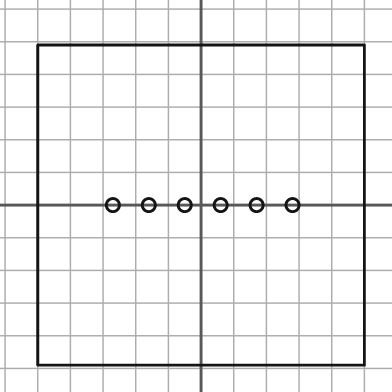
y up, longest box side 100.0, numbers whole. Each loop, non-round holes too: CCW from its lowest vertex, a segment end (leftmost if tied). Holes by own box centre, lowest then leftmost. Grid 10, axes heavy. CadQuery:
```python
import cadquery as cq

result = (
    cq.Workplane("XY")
    .moveTo(-50.0, -49.0)
    .lineTo(50.0, -49.0)
    .lineTo(50.0, 49.0)
    .lineTo(-50.0, 49.0)
    .close()
    .moveTo(-27.0, 0.0)
    .circle(2.0)
    .moveTo(-16.0, 0.0)
    .circle(2.0)
    .moveTo(-5.0, 0.0)
    .circle(2.0)
    .moveTo(6.0, 0.0)
    .circle(2.0)
    .moveTo(17.0, 0.0)
    .circle(2.0)
    .moveTo(28.0, 0.0)
    .circle(2.0)
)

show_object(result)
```